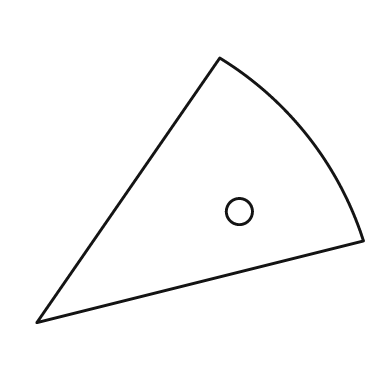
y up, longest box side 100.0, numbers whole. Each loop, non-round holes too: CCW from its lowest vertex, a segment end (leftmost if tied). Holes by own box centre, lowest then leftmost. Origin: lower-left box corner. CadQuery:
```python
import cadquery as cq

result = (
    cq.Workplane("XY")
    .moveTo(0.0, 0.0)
    .lineTo(100.0, 25.0)
    .threePointArc((83.0, 57.0), (56.0, 81.0))
    .close()
    .moveTo(62.0, 34.0)
    .circle(4.0)
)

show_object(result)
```